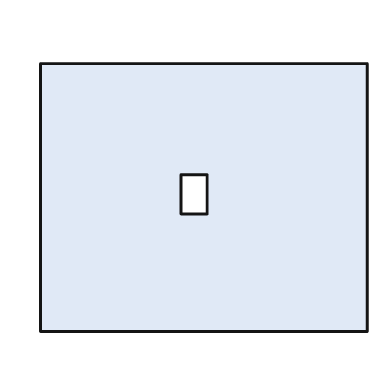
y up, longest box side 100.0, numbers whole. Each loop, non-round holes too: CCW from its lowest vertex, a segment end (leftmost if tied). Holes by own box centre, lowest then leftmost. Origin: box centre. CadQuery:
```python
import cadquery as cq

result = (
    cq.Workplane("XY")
    .moveTo(-50.0, -41.0)
    .lineTo(50.0, -41.0)
    .lineTo(50.0, 41.0)
    .lineTo(-50.0, 41.0)
    .close()
    .moveTo(-7.0, -5.0)
    .lineTo(1.0, -5.0)
    .lineTo(1.0, 7.0)
    .lineTo(-7.0, 7.0)
    .close()
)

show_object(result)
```